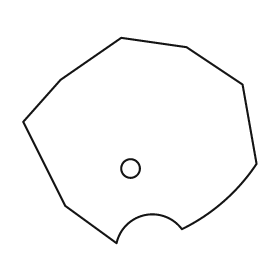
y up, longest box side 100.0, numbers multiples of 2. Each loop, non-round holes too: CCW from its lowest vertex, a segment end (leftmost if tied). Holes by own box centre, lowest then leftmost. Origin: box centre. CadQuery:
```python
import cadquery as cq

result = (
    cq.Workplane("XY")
    .moveTo(-10.0, -44.0)
    .threePointArc((2.0, -32.0), (18.0, -38.0))
    .threePointArc((36.0, -26.0), (50.0, -10.0))
    .lineTo(44.0, 24.0)
    .lineTo(20.0, 40.0)
    .lineTo(-8.0, 44.0)
    .lineTo(-34.0, 26.0)
    .lineTo(-50.0, 8.0)
    .lineTo(-32.0, -28.0)
    .close()
    .moveTo(-4.0, -12.0)
    .circle(4.0)
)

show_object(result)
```